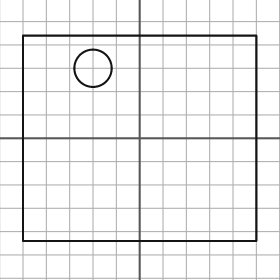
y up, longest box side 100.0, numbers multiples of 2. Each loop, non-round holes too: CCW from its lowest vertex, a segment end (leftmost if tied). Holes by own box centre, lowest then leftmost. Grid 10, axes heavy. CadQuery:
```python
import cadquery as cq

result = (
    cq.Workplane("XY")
    .moveTo(-50.0, -44.0)
    .lineTo(50.0, -44.0)
    .lineTo(50.0, 44.0)
    .lineTo(-50.0, 44.0)
    .close()
    .moveTo(-20.0, 30.0)
    .circle(8.0)
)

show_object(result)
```